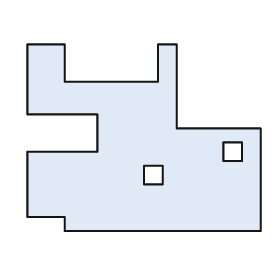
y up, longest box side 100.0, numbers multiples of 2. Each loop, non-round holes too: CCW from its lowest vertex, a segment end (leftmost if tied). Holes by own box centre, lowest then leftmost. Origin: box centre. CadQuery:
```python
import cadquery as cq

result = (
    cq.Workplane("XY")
    .moveTo(-34.0, -40.0)
    .lineTo(50.0, -40.0)
    .lineTo(50.0, 4.0)
    .lineTo(14.0, 4.0)
    .lineTo(14.0, 40.0)
    .lineTo(6.0, 40.0)
    .lineTo(6.0, 24.0)
    .lineTo(-34.0, 24.0)
    .lineTo(-34.0, 40.0)
    .lineTo(-50.0, 40.0)
    .lineTo(-50.0, 10.0)
    .lineTo(-20.0, 10.0)
    .lineTo(-20.0, -6.0)
    .lineTo(-50.0, -6.0)
    .lineTo(-50.0, -34.0)
    .lineTo(-34.0, -34.0)
    .close()
    .moveTo(0.0, -20.0)
    .lineTo(8.0, -20.0)
    .lineTo(8.0, -12.0)
    .lineTo(0.0, -12.0)
    .close()
    .moveTo(34.0, -10.0)
    .lineTo(42.0, -10.0)
    .lineTo(42.0, -2.0)
    .lineTo(34.0, -2.0)
    .close()
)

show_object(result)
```